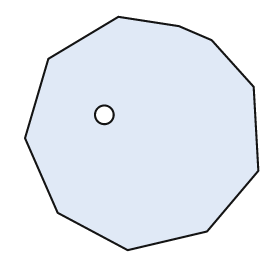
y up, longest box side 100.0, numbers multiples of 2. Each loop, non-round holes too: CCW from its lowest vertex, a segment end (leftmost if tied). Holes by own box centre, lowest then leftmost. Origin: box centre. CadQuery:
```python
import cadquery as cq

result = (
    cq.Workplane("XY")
    .moveTo(-6.0, -50.0)
    .lineTo(28.0, -42.0)
    .lineTo(50.0, -16.0)
    .lineTo(48.0, 20.0)
    .lineTo(30.0, 40.0)
    .lineTo(16.0, 46.0)
    .lineTo(-10.0, 50.0)
    .lineTo(-40.0, 32.0)
    .lineTo(-50.0, -2.0)
    .lineTo(-36.0, -34.0)
    .close()
    .moveTo(-16.0, 8.0)
    .circle(4.0)
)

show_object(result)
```